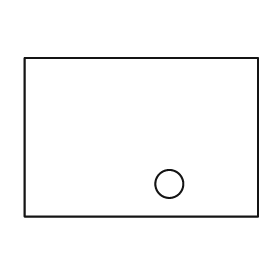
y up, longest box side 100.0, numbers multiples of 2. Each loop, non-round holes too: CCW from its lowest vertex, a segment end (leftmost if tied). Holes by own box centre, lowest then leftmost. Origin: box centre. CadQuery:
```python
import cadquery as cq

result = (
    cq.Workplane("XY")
    .moveTo(-50.0, -34.0)
    .lineTo(50.0, -34.0)
    .lineTo(50.0, 34.0)
    .lineTo(-50.0, 34.0)
    .close()
    .moveTo(12.0, -20.0)
    .circle(6.0)
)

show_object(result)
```